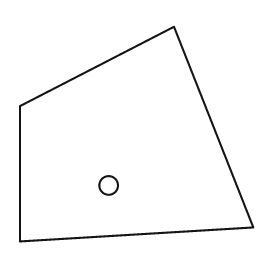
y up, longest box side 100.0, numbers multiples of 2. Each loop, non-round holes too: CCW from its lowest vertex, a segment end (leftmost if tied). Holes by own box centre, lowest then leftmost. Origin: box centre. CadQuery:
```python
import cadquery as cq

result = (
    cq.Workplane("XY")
    .moveTo(-50.0, -46.0)
    .lineTo(50.0, -40.0)
    .lineTo(16.0, 46.0)
    .lineTo(-50.0, 12.0)
    .close()
    .moveTo(-12.0, -22.0)
    .circle(4.0)
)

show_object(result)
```